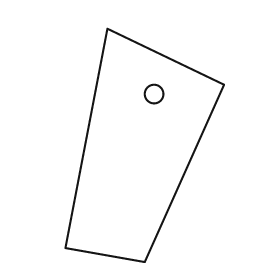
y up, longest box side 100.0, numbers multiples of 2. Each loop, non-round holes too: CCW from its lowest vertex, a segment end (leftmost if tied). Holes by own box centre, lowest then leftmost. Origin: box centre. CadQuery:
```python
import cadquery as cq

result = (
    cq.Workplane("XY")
    .moveTo(0.0, -50.0)
    .lineTo(34.0, 26.0)
    .lineTo(-16.0, 50.0)
    .lineTo(-34.0, -44.0)
    .close()
    .moveTo(4.0, 22.0)
    .circle(4.0)
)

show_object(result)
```